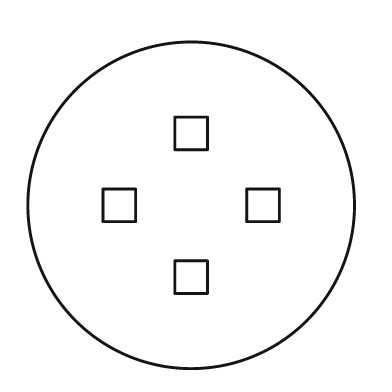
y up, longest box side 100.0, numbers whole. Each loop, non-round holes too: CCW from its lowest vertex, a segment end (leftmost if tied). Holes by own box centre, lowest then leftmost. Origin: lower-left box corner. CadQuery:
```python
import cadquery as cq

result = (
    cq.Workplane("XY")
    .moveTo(50.0, 50.0)
    .circle(50.0)
    .moveTo(45.0, 23.0)
    .lineTo(55.0, 23.0)
    .lineTo(55.0, 33.0)
    .lineTo(45.0, 33.0)
    .close()
    .moveTo(23.0, 45.0)
    .lineTo(33.0, 45.0)
    .lineTo(33.0, 55.0)
    .lineTo(23.0, 55.0)
    .close()
    .moveTo(67.0, 45.0)
    .lineTo(77.0, 45.0)
    .lineTo(77.0, 55.0)
    .lineTo(67.0, 55.0)
    .close()
    .moveTo(45.0, 67.0)
    .lineTo(55.0, 67.0)
    .lineTo(55.0, 77.0)
    .lineTo(45.0, 77.0)
    .close()
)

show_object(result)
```